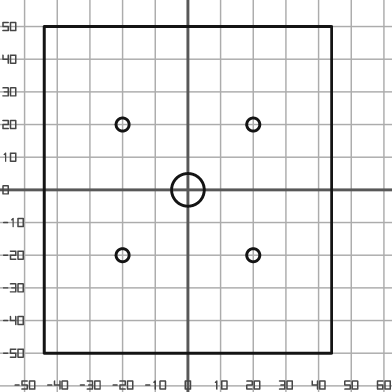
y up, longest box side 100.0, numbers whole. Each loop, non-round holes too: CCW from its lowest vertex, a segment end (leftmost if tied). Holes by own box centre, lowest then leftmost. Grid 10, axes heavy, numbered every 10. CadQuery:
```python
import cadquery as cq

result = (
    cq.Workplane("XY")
    .moveTo(-44.0, -50.0)
    .lineTo(44.0, -50.0)
    .lineTo(44.0, 50.0)
    .lineTo(-44.0, 50.0)
    .close()
    .moveTo(-20.0, -20.0)
    .circle(2.0)
    .moveTo(20.0, -20.0)
    .circle(2.0)
    .moveTo(0.0, 0.0)
    .circle(5.0)
    .moveTo(-20.0, 20.0)
    .circle(2.0)
    .moveTo(20.0, 20.0)
    .circle(2.0)
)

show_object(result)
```